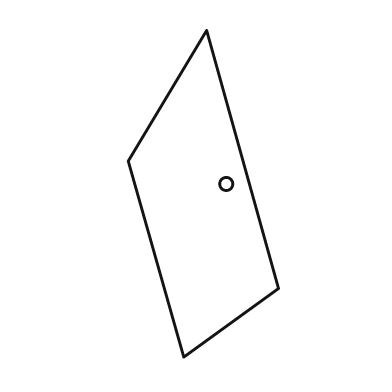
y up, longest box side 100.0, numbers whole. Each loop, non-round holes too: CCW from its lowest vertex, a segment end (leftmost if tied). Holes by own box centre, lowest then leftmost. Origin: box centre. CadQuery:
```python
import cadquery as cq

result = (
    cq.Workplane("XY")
    .moveTo(-6.0, -50.0)
    .lineTo(23.0, -29.0)
    .lineTo(1.0, 50.0)
    .lineTo(-23.0, 10.0)
    .close()
    .moveTo(7.0, 3.0)
    .circle(2.0)
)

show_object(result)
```